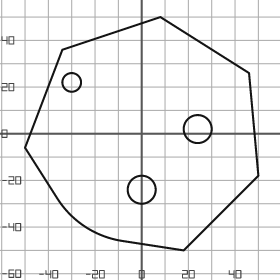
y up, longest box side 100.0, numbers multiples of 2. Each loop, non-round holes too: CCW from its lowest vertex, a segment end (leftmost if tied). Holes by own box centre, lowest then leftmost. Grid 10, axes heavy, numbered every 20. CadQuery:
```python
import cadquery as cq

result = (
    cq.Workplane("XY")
    .moveTo(18.0, -50.0)
    .lineTo(50.0, -18.0)
    .lineTo(46.0, 26.0)
    .lineTo(8.0, 50.0)
    .lineTo(-34.0, 36.0)
    .lineTo(-50.0, -6.0)
    .lineTo(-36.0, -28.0)
    .threePointArc((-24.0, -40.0), (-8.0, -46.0))
    .close()
    .moveTo(0.0, -24.0)
    .circle(6.0)
    .moveTo(24.0, 2.0)
    .circle(6.0)
    .moveTo(-30.0, 22.0)
    .circle(4.0)
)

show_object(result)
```